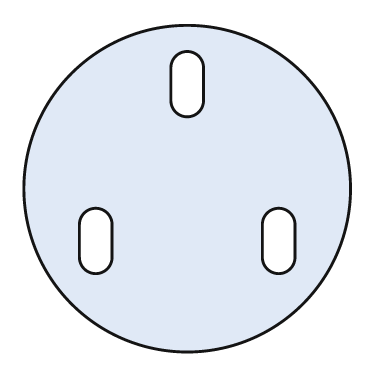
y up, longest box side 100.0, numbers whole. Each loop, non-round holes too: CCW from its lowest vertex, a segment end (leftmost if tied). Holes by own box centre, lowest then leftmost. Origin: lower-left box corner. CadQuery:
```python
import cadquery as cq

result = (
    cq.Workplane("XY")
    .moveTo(50.0, 50.0)
    .circle(50.0)
    .moveTo(17.0, 29.0)
    .threePointArc((22.0, 24.0), (27.0, 29.0))
    .lineTo(27.0, 39.0)
    .threePointArc((22.0, 44.0), (17.0, 39.0))
    .close()
    .moveTo(73.0, 29.0)
    .threePointArc((78.0, 24.0), (83.0, 29.0))
    .lineTo(83.0, 39.0)
    .threePointArc((78.0, 44.0), (73.0, 39.0))
    .close()
    .moveTo(45.0, 77.0)
    .threePointArc((50.0, 72.0), (55.0, 77.0))
    .lineTo(55.0, 87.0)
    .threePointArc((50.0, 92.0), (45.0, 87.0))
    .close()
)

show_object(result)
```